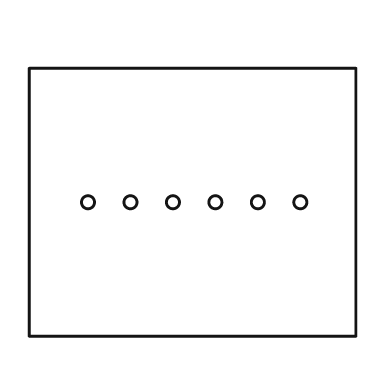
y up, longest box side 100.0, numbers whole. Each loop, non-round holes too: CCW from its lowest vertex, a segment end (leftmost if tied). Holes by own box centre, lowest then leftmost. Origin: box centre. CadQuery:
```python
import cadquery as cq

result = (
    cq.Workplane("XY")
    .moveTo(-50.0, -41.0)
    .lineTo(50.0, -41.0)
    .lineTo(50.0, 41.0)
    .lineTo(-50.0, 41.0)
    .close()
    .moveTo(-32.0, 0.0)
    .circle(2.0)
    .moveTo(-19.0, 0.0)
    .circle(2.0)
    .moveTo(-6.0, 0.0)
    .circle(2.0)
    .moveTo(7.0, 0.0)
    .circle(2.0)
    .moveTo(20.0, 0.0)
    .circle(2.0)
    .moveTo(33.0, 0.0)
    .circle(2.0)
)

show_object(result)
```